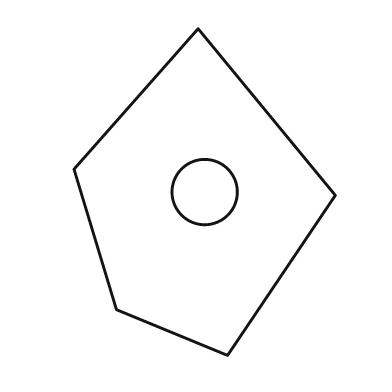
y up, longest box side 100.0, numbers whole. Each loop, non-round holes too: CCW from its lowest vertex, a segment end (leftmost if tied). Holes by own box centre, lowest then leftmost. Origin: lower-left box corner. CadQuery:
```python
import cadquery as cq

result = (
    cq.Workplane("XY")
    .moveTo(47.0, 0.0)
    .lineTo(80.0, 49.0)
    .lineTo(38.0, 100.0)
    .lineTo(0.0, 57.0)
    .lineTo(13.0, 14.0)
    .close()
    .moveTo(40.0, 50.0)
    .circle(10.0)
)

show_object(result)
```